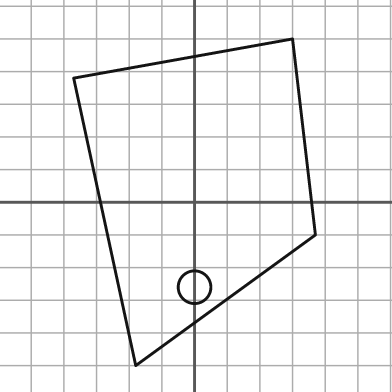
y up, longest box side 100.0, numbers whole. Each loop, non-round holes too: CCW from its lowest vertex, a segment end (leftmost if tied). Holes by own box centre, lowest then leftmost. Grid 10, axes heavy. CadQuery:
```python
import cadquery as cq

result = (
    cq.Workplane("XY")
    .moveTo(-18.0, -50.0)
    .lineTo(37.0, -10.0)
    .lineTo(30.0, 50.0)
    .lineTo(-37.0, 38.0)
    .close()
    .moveTo(0.0, -26.0)
    .circle(5.0)
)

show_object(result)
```